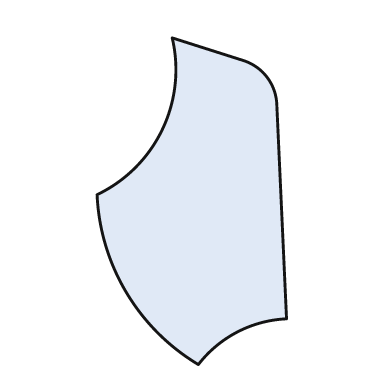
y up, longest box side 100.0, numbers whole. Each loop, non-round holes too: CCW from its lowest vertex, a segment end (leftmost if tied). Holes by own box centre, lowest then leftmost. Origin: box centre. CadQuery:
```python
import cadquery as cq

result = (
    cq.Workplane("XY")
    .moveTo(2.0, -50.0)
    .threePointArc((14.0, -40.0), (29.0, -36.0))
    .lineTo(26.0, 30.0)
    .threePointArc((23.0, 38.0), (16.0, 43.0))
    .lineTo(-6.0, 50.0)
    .threePointArc((-9.0, 22.0), (-29.0, 2.0))
    .threePointArc((-20.0, -28.0), (2.0, -50.0))
    .close()
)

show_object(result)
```